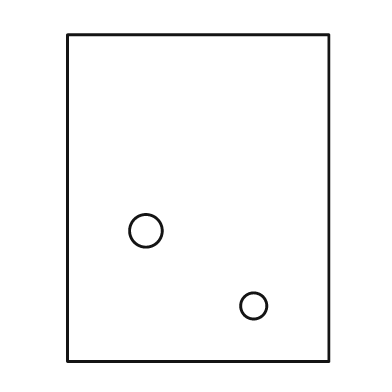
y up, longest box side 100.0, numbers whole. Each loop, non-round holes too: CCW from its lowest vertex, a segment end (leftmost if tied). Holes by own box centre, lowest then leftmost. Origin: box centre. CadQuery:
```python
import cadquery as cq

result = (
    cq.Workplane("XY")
    .moveTo(-40.0, -50.0)
    .lineTo(40.0, -50.0)
    .lineTo(40.0, 50.0)
    .lineTo(-40.0, 50.0)
    .close()
    .moveTo(17.0, -33.0)
    .circle(4.0)
    .moveTo(-16.0, -10.0)
    .circle(5.0)
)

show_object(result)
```